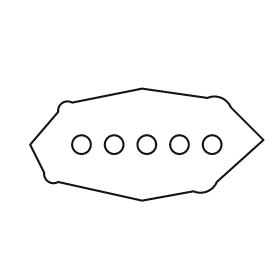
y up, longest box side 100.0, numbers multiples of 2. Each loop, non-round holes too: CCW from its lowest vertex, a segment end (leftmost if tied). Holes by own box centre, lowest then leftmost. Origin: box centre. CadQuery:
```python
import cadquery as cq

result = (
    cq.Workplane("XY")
    .moveTo(-2.0, -24.0)
    .lineTo(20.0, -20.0)
    .threePointArc((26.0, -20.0), (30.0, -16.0))
    .lineTo(50.0, 2.0)
    .lineTo(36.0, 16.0)
    .threePointArc((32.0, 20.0), (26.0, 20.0))
    .lineTo(-2.0, 24.0)
    .lineTo(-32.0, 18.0)
    .threePointArc((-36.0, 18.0), (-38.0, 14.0))
    .lineTo(-50.0, 0.0)
    .lineTo(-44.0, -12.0)
    .threePointArc((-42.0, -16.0), (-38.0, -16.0))
    .close()
    .moveTo(-28.0, 0.0)
    .circle(4.0)
    .moveTo(-14.0, 0.0)
    .circle(4.0)
    .moveTo(0.0, 0.0)
    .circle(4.0)
    .moveTo(14.0, 0.0)
    .circle(4.0)
    .moveTo(28.0, 0.0)
    .circle(4.0)
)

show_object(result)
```